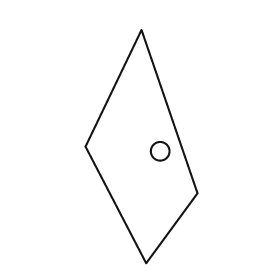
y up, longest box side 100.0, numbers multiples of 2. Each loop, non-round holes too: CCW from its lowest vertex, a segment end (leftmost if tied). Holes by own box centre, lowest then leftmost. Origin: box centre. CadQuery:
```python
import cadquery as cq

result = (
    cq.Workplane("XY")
    .moveTo(2.0, -50.0)
    .lineTo(24.0, -20.0)
    .lineTo(0.0, 50.0)
    .lineTo(-24.0, 0.0)
    .close()
    .moveTo(8.0, -2.0)
    .circle(4.0)
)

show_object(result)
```